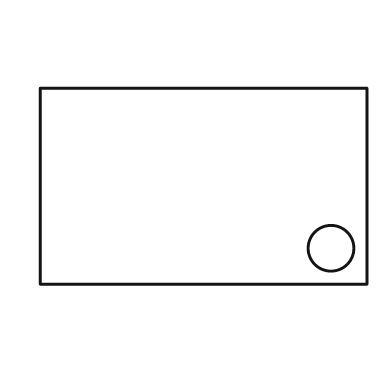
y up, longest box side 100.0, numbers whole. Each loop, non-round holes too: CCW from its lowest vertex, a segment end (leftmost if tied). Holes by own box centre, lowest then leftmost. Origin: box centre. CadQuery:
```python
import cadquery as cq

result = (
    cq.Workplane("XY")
    .moveTo(-50.0, -30.0)
    .lineTo(50.0, -30.0)
    .lineTo(50.0, 30.0)
    .lineTo(-50.0, 30.0)
    .close()
    .moveTo(39.0, -19.0)
    .circle(7.0)
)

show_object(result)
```